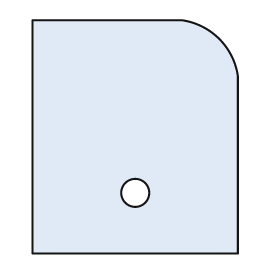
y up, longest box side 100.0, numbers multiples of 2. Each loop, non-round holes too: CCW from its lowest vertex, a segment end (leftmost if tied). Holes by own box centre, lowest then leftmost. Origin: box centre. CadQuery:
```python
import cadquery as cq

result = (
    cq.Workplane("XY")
    .moveTo(-44.0, -50.0)
    .lineTo(44.0, -50.0)
    .lineTo(44.0, 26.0)
    .threePointArc((36.0, 42.0), (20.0, 50.0))
    .lineTo(-44.0, 50.0)
    .close()
    .moveTo(0.0, -24.0)
    .circle(6.0)
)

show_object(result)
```